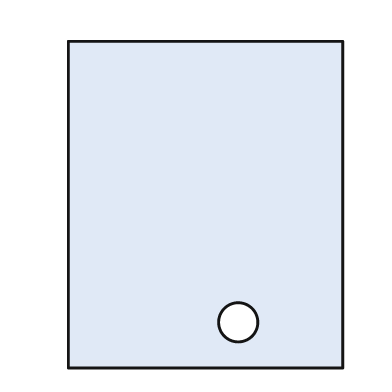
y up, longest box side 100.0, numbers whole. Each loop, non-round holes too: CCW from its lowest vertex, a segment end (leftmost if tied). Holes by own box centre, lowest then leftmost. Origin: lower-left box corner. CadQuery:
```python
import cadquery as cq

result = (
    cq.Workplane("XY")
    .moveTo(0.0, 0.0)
    .lineTo(84.0, 0.0)
    .lineTo(84.0, 100.0)
    .lineTo(0.0, 100.0)
    .close()
    .moveTo(52.0, 14.0)
    .circle(6.0)
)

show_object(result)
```